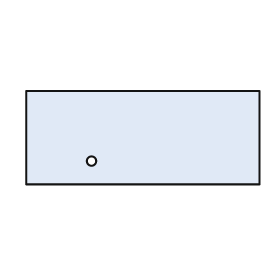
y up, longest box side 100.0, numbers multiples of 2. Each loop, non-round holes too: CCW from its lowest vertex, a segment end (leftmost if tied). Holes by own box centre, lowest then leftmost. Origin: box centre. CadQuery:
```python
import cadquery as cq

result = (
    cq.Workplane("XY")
    .moveTo(-50.0, -20.0)
    .lineTo(50.0, -20.0)
    .lineTo(50.0, 20.0)
    .lineTo(-50.0, 20.0)
    .close()
    .moveTo(-22.0, -10.0)
    .circle(2.0)
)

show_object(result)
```